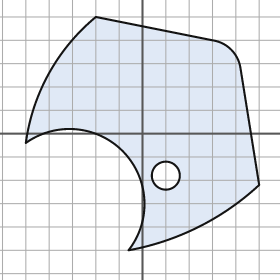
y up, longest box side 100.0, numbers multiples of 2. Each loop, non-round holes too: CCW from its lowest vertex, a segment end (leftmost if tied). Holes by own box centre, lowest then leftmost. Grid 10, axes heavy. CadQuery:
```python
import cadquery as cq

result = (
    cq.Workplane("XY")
    .moveTo(-6.0, -50.0)
    .threePointArc((24.0, -40.0), (50.0, -22.0))
    .lineTo(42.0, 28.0)
    .threePointArc((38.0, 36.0), (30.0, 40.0))
    .lineTo(-20.0, 50.0)
    .threePointArc((-40.0, 26.0), (-50.0, -4.0))
    .threePointArc((-8.0, -8.0), (-6.0, -50.0))
    .close()
    .moveTo(10.0, -18.0)
    .circle(6.0)
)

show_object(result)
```